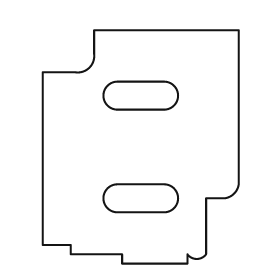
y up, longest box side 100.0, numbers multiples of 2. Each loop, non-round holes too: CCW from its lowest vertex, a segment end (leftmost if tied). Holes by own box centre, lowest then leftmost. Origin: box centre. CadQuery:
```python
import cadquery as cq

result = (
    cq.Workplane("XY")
    .moveTo(-8.0, -50.0)
    .lineTo(20.0, -50.0)
    .lineTo(20.0, -46.0)
    .threePointArc((24.0, -48.0), (28.0, -46.0))
    .lineTo(28.0, -22.0)
    .lineTo(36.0, -22.0)
    .threePointArc((40.0, -20.0), (42.0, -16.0))
    .lineTo(42.0, 50.0)
    .lineTo(-20.0, 50.0)
    .lineTo(-20.0, 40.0)
    .threePointArc((-22.0, 34.0), (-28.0, 32.0))
    .lineTo(-42.0, 32.0)
    .lineTo(-42.0, -42.0)
    .lineTo(-30.0, -42.0)
    .lineTo(-30.0, -46.0)
    .lineTo(-8.0, -46.0)
    .close()
    .moveTo(-10.0, -28.0)
    .lineTo(10.0, -28.0)
    .threePointArc((16.0, -22.0), (10.0, -16.0))
    .lineTo(-10.0, -16.0)
    .threePointArc((-16.0, -22.0), (-10.0, -28.0))
    .close()
    .moveTo(-10.0, 16.0)
    .lineTo(10.0, 16.0)
    .threePointArc((16.0, 22.0), (10.0, 28.0))
    .lineTo(-10.0, 28.0)
    .threePointArc((-16.0, 22.0), (-10.0, 16.0))
    .close()
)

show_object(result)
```